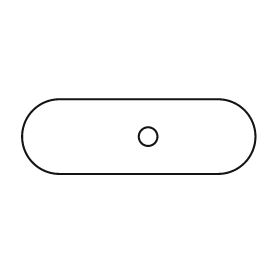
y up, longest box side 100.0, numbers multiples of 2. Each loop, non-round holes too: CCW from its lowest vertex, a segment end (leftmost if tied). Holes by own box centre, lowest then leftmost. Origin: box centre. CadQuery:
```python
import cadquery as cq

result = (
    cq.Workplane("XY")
    .moveTo(-34.0, -16.0)
    .lineTo(34.0, -16.0)
    .threePointArc((50.0, 0.0), (34.0, 16.0))
    .lineTo(-34.0, 16.0)
    .threePointArc((-50.0, 0.0), (-34.0, -16.0))
    .close()
    .moveTo(4.0, 0.0)
    .circle(4.0)
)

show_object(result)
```